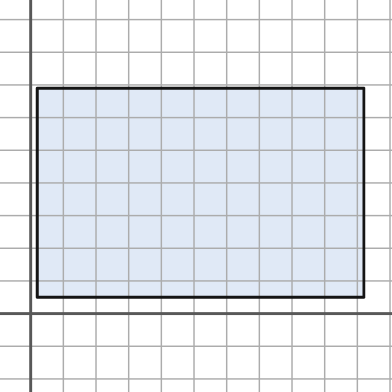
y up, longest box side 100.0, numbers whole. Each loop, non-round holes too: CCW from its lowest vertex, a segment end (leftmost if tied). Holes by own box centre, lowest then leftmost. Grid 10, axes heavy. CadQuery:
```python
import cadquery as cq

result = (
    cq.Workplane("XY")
    .moveTo(2.0, 5.0)
    .lineTo(102.0, 5.0)
    .lineTo(102.0, 69.0)
    .lineTo(2.0, 69.0)
    .close()
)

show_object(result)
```